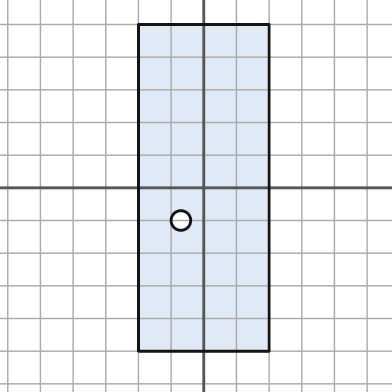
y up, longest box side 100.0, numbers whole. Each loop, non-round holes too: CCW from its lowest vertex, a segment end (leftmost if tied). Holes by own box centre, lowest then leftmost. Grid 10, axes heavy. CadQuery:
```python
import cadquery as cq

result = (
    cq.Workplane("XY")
    .moveTo(-20.0, -50.0)
    .lineTo(20.0, -50.0)
    .lineTo(20.0, 50.0)
    .lineTo(-20.0, 50.0)
    .close()
    .moveTo(-7.0, -10.0)
    .circle(3.0)
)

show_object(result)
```